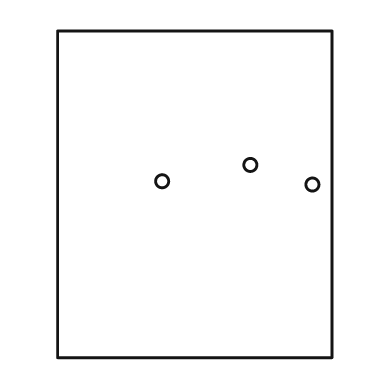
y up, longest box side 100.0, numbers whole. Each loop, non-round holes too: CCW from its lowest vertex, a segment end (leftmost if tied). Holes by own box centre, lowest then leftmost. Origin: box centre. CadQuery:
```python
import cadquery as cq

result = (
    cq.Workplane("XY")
    .moveTo(-42.0, -50.0)
    .lineTo(42.0, -50.0)
    .lineTo(42.0, 50.0)
    .lineTo(-42.0, 50.0)
    .close()
    .moveTo(36.0, 3.0)
    .circle(2.0)
    .moveTo(-10.0, 4.0)
    .circle(2.0)
    .moveTo(17.0, 9.0)
    .circle(2.0)
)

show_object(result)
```